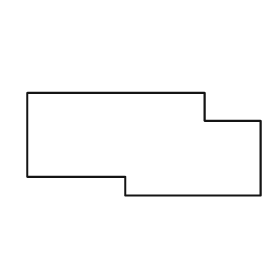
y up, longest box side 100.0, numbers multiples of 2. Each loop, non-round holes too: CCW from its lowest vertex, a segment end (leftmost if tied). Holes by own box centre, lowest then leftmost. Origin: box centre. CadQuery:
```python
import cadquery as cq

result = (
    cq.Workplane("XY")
    .moveTo(-8.0, -22.0)
    .lineTo(50.0, -22.0)
    .lineTo(50.0, 10.0)
    .lineTo(26.0, 10.0)
    .lineTo(26.0, 22.0)
    .lineTo(-50.0, 22.0)
    .lineTo(-50.0, -14.0)
    .lineTo(-8.0, -14.0)
    .close()
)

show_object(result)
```